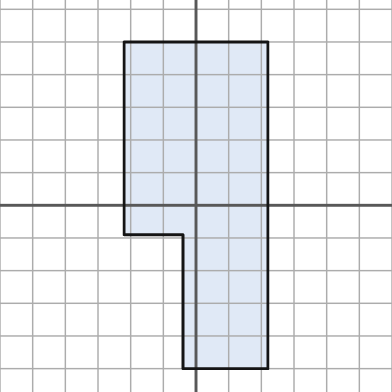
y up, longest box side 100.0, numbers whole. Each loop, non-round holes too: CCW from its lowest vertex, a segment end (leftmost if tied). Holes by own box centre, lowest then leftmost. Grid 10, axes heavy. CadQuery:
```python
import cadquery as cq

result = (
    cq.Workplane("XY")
    .moveTo(-4.0, -50.0)
    .lineTo(22.0, -50.0)
    .lineTo(22.0, 50.0)
    .lineTo(-22.0, 50.0)
    .lineTo(-22.0, -9.0)
    .lineTo(-4.0, -9.0)
    .close()
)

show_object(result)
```